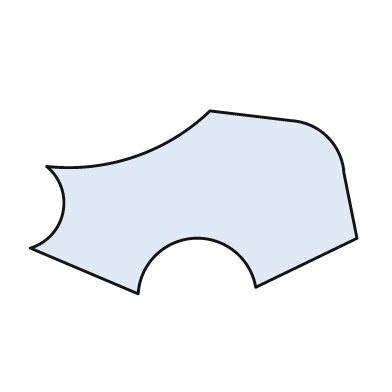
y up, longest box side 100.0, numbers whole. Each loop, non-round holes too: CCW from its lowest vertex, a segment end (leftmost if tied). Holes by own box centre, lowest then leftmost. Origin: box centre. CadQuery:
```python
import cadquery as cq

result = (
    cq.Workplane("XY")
    .moveTo(-17.0, -28.0)
    .threePointArc((0.0, -11.0), (19.0, -26.0))
    .lineTo(50.0, -11.0)
    .lineTo(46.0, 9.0)
    .threePointArc((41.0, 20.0), (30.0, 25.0))
    .lineTo(5.0, 28.0)
    .threePointArc((-18.0, 14.0), (-45.0, 11.0))
    .threePointArc((-40.0, -3.0), (-50.0, -14.0))
    .close()
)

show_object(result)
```